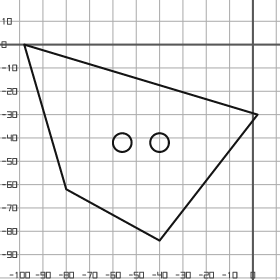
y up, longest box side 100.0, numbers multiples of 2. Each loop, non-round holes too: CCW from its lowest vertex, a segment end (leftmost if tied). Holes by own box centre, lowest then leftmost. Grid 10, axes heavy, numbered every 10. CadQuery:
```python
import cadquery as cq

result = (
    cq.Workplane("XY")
    .moveTo(-40.0, -84.0)
    .lineTo(2.0, -30.0)
    .lineTo(-98.0, 0.0)
    .lineTo(-80.0, -62.0)
    .close()
    .moveTo(-56.0, -42.0)
    .circle(4.0)
    .moveTo(-40.0, -42.0)
    .circle(4.0)
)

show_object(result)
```